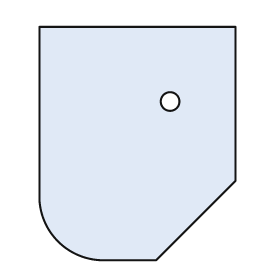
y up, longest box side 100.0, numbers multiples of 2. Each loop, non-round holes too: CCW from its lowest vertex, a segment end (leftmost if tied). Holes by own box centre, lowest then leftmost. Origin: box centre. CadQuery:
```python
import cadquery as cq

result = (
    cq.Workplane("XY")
    .moveTo(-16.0, -50.0)
    .lineTo(8.0, -50.0)
    .lineTo(42.0, -16.0)
    .lineTo(42.0, 50.0)
    .lineTo(-42.0, 50.0)
    .lineTo(-42.0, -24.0)
    .threePointArc((-34.0, -42.0), (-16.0, -50.0))
    .close()
    .moveTo(14.0, 18.0)
    .circle(4.0)
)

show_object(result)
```